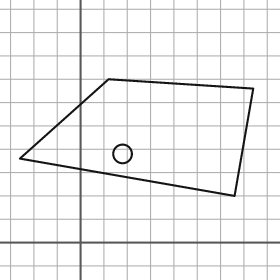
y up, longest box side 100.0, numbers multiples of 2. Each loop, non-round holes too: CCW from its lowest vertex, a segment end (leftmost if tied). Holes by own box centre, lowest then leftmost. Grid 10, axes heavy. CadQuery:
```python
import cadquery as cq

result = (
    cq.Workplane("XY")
    .moveTo(66.0, 20.0)
    .lineTo(74.0, 66.0)
    .lineTo(12.0, 70.0)
    .lineTo(-26.0, 36.0)
    .close()
    .moveTo(18.0, 38.0)
    .circle(4.0)
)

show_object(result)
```